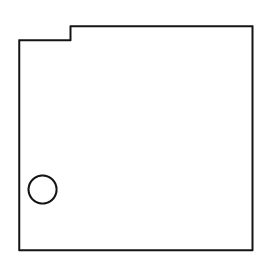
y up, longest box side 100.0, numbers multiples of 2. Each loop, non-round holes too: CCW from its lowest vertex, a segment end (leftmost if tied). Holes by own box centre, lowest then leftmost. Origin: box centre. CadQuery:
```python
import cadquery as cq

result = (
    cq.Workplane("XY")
    .moveTo(-50.0, -48.0)
    .lineTo(50.0, -48.0)
    .lineTo(50.0, 48.0)
    .lineTo(-28.0, 48.0)
    .lineTo(-28.0, 42.0)
    .lineTo(-50.0, 42.0)
    .close()
    .moveTo(-40.0, -22.0)
    .circle(6.0)
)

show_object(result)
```